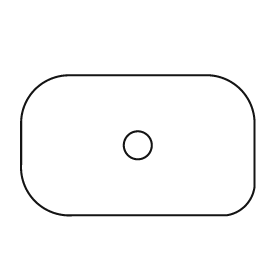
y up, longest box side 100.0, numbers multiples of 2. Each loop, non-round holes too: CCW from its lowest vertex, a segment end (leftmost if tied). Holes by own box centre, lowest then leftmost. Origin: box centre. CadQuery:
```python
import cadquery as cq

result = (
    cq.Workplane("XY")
    .moveTo(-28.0, -30.0)
    .lineTo(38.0, -30.0)
    .threePointArc((46.0, -26.0), (50.0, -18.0))
    .lineTo(50.0, 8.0)
    .threePointArc((44.0, 24.0), (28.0, 30.0))
    .lineTo(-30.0, 30.0)
    .threePointArc((-44.0, 24.0), (-50.0, 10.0))
    .lineTo(-50.0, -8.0)
    .threePointArc((-44.0, -24.0), (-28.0, -30.0))
    .close()
    .moveTo(0.0, 0.0)
    .circle(6.0)
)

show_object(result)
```